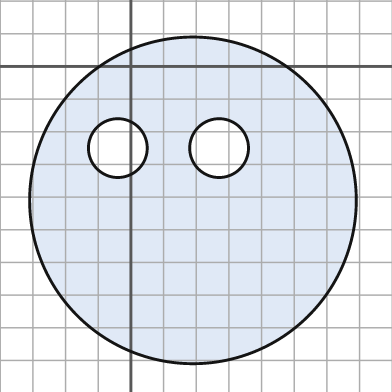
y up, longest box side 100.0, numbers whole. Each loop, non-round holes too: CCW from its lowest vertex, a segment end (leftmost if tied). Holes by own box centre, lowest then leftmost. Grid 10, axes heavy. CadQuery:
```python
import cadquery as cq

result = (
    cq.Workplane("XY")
    .moveTo(19.0, -41.0)
    .circle(50.0)
    .moveTo(-4.0, -25.0)
    .circle(9.0)
    .moveTo(27.0, -25.0)
    .circle(9.0)
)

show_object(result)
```